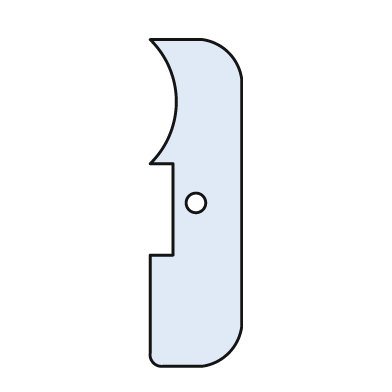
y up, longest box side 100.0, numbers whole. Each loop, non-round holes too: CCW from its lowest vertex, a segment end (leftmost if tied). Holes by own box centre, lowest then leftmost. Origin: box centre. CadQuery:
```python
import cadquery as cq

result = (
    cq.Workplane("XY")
    .moveTo(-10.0, -50.0)
    .lineTo(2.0, -50.0)
    .threePointArc((10.0, -46.0), (14.0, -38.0))
    .lineTo(14.0, 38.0)
    .threePointArc((10.0, 46.0), (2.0, 50.0))
    .lineTo(-14.0, 50.0)
    .threePointArc((-6.0, 31.0), (-14.0, 12.0))
    .lineTo(-7.0, 12.0)
    .lineTo(-7.0, -16.0)
    .lineTo(-14.0, -16.0)
    .lineTo(-14.0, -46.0)
    .threePointArc((-13.0, -49.0), (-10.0, -50.0))
    .close()
    .moveTo(0.0, 0.0)
    .circle(3.0)
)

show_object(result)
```